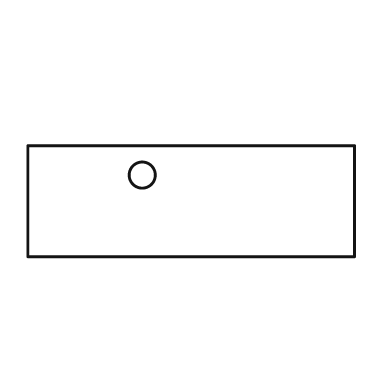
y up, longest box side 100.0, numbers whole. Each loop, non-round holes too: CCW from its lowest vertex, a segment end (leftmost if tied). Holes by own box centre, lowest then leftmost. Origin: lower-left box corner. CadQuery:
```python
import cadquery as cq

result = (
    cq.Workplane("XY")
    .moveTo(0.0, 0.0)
    .lineTo(100.0, 0.0)
    .lineTo(100.0, 34.0)
    .lineTo(0.0, 34.0)
    .close()
    .moveTo(35.0, 25.0)
    .circle(4.0)
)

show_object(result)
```